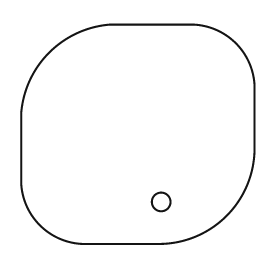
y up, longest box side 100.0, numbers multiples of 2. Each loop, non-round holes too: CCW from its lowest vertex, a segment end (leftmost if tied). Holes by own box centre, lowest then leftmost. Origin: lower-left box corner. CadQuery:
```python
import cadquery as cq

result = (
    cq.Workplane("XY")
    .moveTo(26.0, 0.0)
    .lineTo(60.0, 0.0)
    .threePointArc((88.0, 12.0), (100.0, 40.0))
    .lineTo(100.0, 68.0)
    .threePointArc((92.0, 86.0), (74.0, 94.0))
    .lineTo(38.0, 94.0)
    .threePointArc((12.0, 82.0), (0.0, 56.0))
    .lineTo(0.0, 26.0)
    .threePointArc((8.0, 8.0), (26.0, 0.0))
    .close()
    .moveTo(60.0, 18.0)
    .circle(4.0)
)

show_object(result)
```